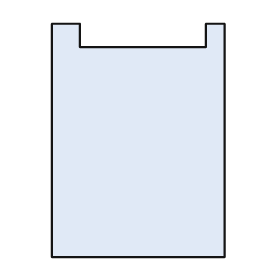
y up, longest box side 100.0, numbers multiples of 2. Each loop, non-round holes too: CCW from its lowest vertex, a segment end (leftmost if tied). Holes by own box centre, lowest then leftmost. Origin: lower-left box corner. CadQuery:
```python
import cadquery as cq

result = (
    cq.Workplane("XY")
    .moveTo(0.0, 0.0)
    .lineTo(74.0, 0.0)
    .lineTo(74.0, 100.0)
    .lineTo(66.0, 100.0)
    .lineTo(66.0, 90.0)
    .lineTo(12.0, 90.0)
    .lineTo(12.0, 100.0)
    .lineTo(0.0, 100.0)
    .close()
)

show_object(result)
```